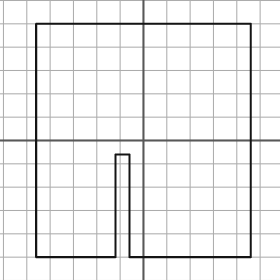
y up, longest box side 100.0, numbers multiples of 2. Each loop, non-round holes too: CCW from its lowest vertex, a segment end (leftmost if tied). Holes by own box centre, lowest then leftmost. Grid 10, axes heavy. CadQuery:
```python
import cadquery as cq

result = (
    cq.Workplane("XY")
    .moveTo(-46.0, -50.0)
    .lineTo(-12.0, -50.0)
    .lineTo(-12.0, -6.0)
    .lineTo(-6.0, -6.0)
    .lineTo(-6.0, -50.0)
    .lineTo(46.0, -50.0)
    .lineTo(46.0, 50.0)
    .lineTo(-46.0, 50.0)
    .close()
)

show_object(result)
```